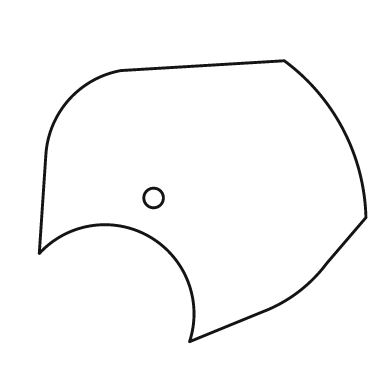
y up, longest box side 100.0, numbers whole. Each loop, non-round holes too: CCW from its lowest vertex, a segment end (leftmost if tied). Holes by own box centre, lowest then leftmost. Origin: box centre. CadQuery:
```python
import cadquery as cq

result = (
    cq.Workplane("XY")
    .moveTo(-4.0, -43.0)
    .lineTo(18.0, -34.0)
    .threePointArc((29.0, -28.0), (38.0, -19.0))
    .lineTo(50.0, -5.0)
    .threePointArc((43.0, 22.0), (25.0, 43.0))
    .lineTo(-25.0, 40.0)
    .threePointArc((-41.0, 31.0), (-48.0, 14.0))
    .lineTo(-50.0, -16.0)
    .threePointArc((-16.0, -11.0), (-4.0, -43.0))
    .close()
    .moveTo(-15.0, 1.0)
    .circle(3.0)
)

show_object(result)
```